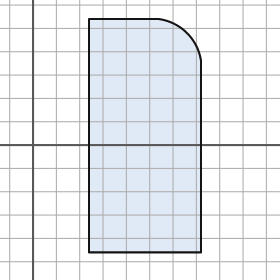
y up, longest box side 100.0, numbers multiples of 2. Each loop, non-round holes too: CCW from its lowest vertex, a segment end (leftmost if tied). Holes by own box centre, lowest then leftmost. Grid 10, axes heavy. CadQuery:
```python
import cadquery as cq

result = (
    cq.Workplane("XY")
    .moveTo(24.0, -46.0)
    .lineTo(72.0, -46.0)
    .lineTo(72.0, 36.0)
    .threePointArc((66.0, 48.0), (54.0, 54.0))
    .lineTo(24.0, 54.0)
    .close()
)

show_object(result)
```